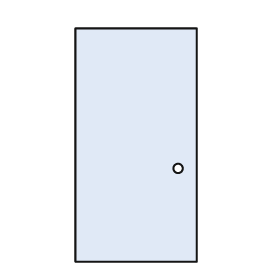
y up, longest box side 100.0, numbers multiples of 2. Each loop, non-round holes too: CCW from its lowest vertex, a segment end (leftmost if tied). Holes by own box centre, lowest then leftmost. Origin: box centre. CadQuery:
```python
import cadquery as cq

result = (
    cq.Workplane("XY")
    .moveTo(-26.0, -50.0)
    .lineTo(26.0, -50.0)
    .lineTo(26.0, 50.0)
    .lineTo(-26.0, 50.0)
    .close()
    .moveTo(18.0, -10.0)
    .circle(2.0)
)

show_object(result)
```